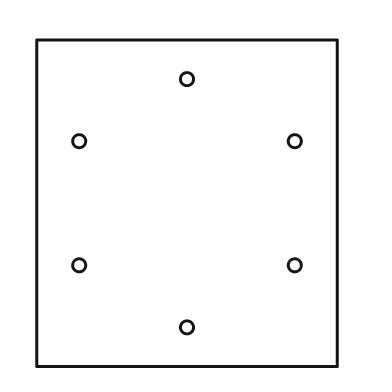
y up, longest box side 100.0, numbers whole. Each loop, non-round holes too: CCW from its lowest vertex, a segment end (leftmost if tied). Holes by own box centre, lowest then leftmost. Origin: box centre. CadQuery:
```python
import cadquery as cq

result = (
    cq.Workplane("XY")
    .moveTo(-46.0, -50.0)
    .lineTo(46.0, -50.0)
    .lineTo(46.0, 50.0)
    .lineTo(-46.0, 50.0)
    .close()
    .moveTo(0.0, -38.0)
    .circle(2.0)
    .moveTo(-33.0, -19.0)
    .circle(2.0)
    .moveTo(33.0, -19.0)
    .circle(2.0)
    .moveTo(-33.0, 19.0)
    .circle(2.0)
    .moveTo(33.0, 19.0)
    .circle(2.0)
    .moveTo(0.0, 38.0)
    .circle(2.0)
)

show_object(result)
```